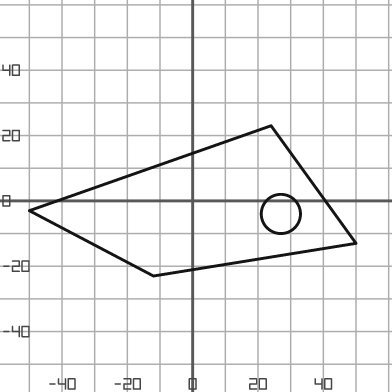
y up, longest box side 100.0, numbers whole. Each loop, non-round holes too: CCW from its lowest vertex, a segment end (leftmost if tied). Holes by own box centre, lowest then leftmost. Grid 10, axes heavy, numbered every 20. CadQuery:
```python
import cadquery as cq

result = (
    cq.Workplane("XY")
    .moveTo(-12.0, -23.0)
    .lineTo(50.0, -13.0)
    .lineTo(24.0, 23.0)
    .lineTo(-50.0, -3.0)
    .close()
    .moveTo(27.0, -4.0)
    .circle(6.0)
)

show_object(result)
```